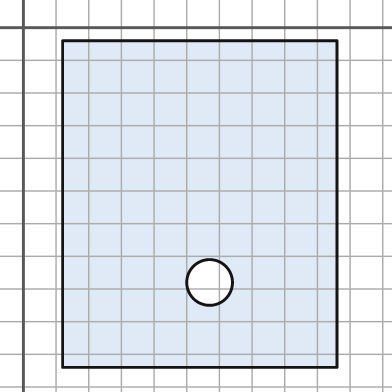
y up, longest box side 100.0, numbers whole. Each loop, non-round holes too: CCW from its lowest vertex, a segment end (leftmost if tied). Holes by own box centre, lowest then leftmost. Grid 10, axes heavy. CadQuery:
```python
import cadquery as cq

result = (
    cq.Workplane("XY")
    .moveTo(12.0, -104.0)
    .lineTo(96.0, -104.0)
    .lineTo(96.0, -4.0)
    .lineTo(12.0, -4.0)
    .close()
    .moveTo(57.0, -78.0)
    .circle(7.0)
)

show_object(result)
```